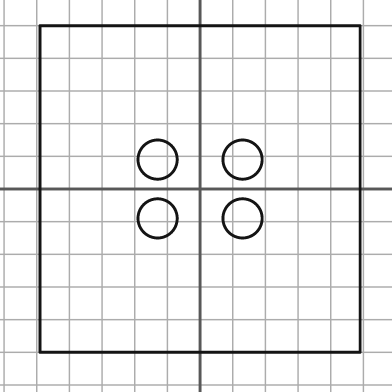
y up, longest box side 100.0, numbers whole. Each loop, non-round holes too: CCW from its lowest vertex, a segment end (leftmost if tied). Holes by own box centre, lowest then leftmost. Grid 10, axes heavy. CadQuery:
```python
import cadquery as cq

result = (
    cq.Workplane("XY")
    .moveTo(-49.0, -50.0)
    .lineTo(49.0, -50.0)
    .lineTo(49.0, 50.0)
    .lineTo(-49.0, 50.0)
    .close()
    .moveTo(-13.0, -9.0)
    .circle(6.0)
    .moveTo(13.0, -9.0)
    .circle(6.0)
    .moveTo(-13.0, 9.0)
    .circle(6.0)
    .moveTo(13.0, 9.0)
    .circle(6.0)
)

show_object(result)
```